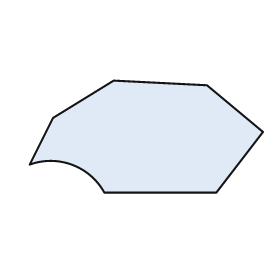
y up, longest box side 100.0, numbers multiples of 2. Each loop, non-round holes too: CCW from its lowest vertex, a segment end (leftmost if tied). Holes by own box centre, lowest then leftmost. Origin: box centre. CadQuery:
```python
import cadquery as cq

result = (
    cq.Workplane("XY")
    .moveTo(-18.0, -24.0)
    .lineTo(30.0, -24.0)
    .lineTo(50.0, 2.0)
    .lineTo(26.0, 22.0)
    .lineTo(-14.0, 24.0)
    .lineTo(-40.0, 8.0)
    .lineTo(-50.0, -12.0)
    .threePointArc((-32.0, -12.0), (-18.0, -24.0))
    .close()
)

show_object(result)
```